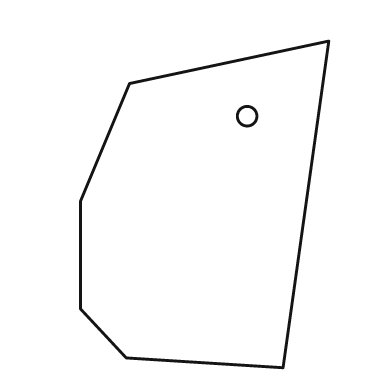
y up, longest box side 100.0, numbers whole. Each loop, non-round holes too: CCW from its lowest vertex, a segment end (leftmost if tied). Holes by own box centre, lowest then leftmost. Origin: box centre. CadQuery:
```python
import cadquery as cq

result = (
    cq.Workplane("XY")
    .moveTo(24.0, -50.0)
    .lineTo(38.0, 50.0)
    .lineTo(-23.0, 37.0)
    .lineTo(-38.0, 1.0)
    .lineTo(-38.0, -32.0)
    .lineTo(-24.0, -47.0)
    .close()
    .moveTo(13.0, 27.0)
    .circle(3.0)
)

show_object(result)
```